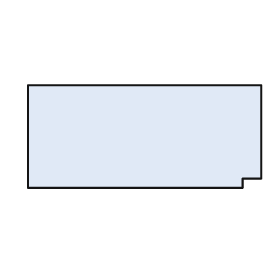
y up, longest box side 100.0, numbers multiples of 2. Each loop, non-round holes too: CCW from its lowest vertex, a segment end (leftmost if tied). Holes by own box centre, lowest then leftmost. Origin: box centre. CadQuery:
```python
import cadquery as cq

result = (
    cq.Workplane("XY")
    .moveTo(-50.0, -22.0)
    .lineTo(42.0, -22.0)
    .lineTo(42.0, -18.0)
    .lineTo(50.0, -18.0)
    .lineTo(50.0, 22.0)
    .lineTo(-50.0, 22.0)
    .close()
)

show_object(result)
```